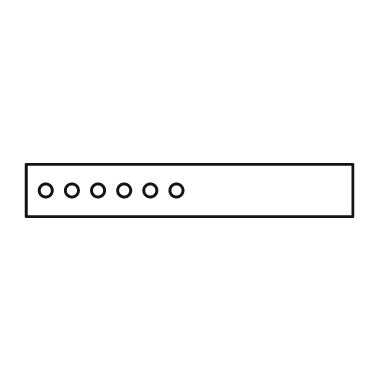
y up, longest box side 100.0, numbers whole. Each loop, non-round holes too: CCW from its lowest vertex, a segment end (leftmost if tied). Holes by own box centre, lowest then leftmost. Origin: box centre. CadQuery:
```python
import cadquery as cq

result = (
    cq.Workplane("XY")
    .moveTo(-50.0, -8.0)
    .lineTo(50.0, -8.0)
    .lineTo(50.0, 8.0)
    .lineTo(-50.0, 8.0)
    .close()
    .moveTo(-44.0, 0.0)
    .circle(2.0)
    .moveTo(-36.0, 0.0)
    .circle(2.0)
    .moveTo(-28.0, 0.0)
    .circle(2.0)
    .moveTo(-20.0, 0.0)
    .circle(2.0)
    .moveTo(-12.0, 0.0)
    .circle(2.0)
    .moveTo(-4.0, 0.0)
    .circle(2.0)
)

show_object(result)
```